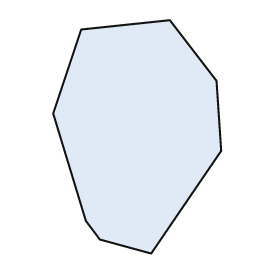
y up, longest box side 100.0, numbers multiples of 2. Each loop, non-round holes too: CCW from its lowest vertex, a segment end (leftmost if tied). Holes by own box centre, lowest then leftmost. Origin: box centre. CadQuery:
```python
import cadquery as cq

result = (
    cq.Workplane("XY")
    .moveTo(6.0, -50.0)
    .lineTo(36.0, -6.0)
    .lineTo(34.0, 24.0)
    .lineTo(14.0, 50.0)
    .lineTo(-24.0, 46.0)
    .lineTo(-36.0, 10.0)
    .lineTo(-22.0, -36.0)
    .lineTo(-16.0, -44.0)
    .close()
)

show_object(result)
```